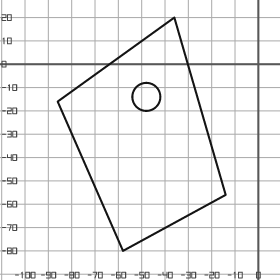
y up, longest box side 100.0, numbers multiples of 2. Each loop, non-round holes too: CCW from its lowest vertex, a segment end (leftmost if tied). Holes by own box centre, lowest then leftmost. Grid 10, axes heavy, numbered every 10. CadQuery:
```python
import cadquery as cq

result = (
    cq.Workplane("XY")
    .moveTo(-58.0, -80.0)
    .lineTo(-14.0, -56.0)
    .lineTo(-36.0, 20.0)
    .lineTo(-86.0, -16.0)
    .close()
    .moveTo(-48.0, -14.0)
    .circle(6.0)
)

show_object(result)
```